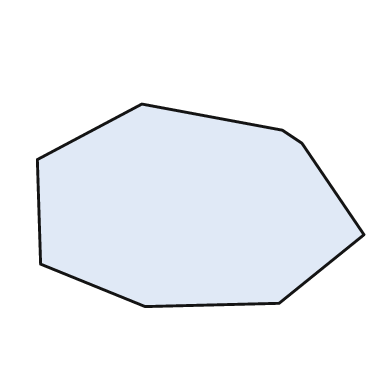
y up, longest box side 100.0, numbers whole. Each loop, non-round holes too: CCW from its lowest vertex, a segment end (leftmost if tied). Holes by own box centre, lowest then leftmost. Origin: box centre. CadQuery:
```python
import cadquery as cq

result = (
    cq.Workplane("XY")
    .moveTo(-17.0, -31.0)
    .lineTo(24.0, -30.0)
    .lineTo(50.0, -9.0)
    .lineTo(31.0, 19.0)
    .lineTo(25.0, 23.0)
    .lineTo(-18.0, 31.0)
    .lineTo(-50.0, 14.0)
    .lineTo(-49.0, -18.0)
    .close()
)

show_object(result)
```